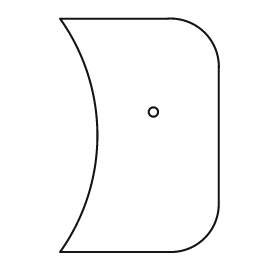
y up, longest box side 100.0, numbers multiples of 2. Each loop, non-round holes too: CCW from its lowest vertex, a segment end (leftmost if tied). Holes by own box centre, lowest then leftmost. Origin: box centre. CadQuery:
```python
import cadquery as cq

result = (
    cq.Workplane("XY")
    .moveTo(-34.0, -50.0)
    .lineTo(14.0, -50.0)
    .threePointArc((28.0, -44.0), (34.0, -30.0))
    .lineTo(34.0, 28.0)
    .threePointArc((28.0, 44.0), (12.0, 50.0))
    .lineTo(-34.0, 50.0)
    .threePointArc((-18.0, 0.0), (-34.0, -50.0))
    .close()
    .moveTo(6.0, 10.0)
    .circle(2.0)
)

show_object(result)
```